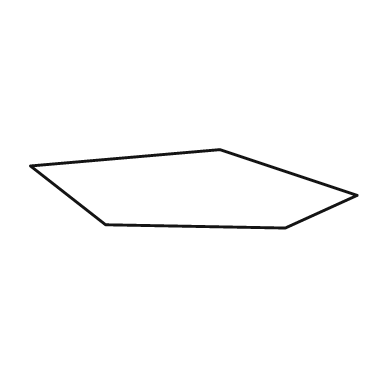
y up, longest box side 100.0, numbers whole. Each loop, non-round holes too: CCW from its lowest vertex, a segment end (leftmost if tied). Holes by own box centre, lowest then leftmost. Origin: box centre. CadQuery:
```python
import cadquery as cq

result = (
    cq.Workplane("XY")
    .moveTo(28.0, -12.0)
    .lineTo(50.0, -2.0)
    .lineTo(8.0, 12.0)
    .lineTo(-50.0, 7.0)
    .lineTo(-27.0, -11.0)
    .close()
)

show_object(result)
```